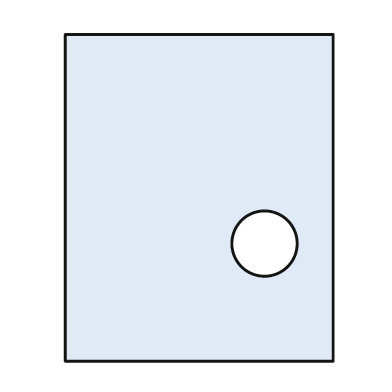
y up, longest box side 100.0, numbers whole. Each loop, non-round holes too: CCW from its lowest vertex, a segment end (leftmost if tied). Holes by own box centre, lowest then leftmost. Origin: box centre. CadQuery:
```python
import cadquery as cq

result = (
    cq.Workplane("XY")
    .moveTo(-41.0, -50.0)
    .lineTo(41.0, -50.0)
    .lineTo(41.0, 50.0)
    .lineTo(-41.0, 50.0)
    .close()
    .moveTo(20.0, -14.0)
    .circle(10.0)
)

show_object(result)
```